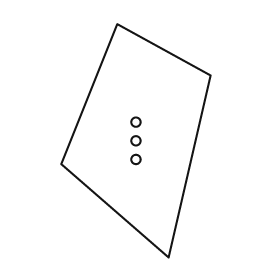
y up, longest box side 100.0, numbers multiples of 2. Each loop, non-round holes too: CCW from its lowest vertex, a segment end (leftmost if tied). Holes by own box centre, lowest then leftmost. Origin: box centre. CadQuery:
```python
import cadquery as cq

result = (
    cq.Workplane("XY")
    .moveTo(14.0, -50.0)
    .lineTo(32.0, 28.0)
    .lineTo(-8.0, 50.0)
    .lineTo(-32.0, -10.0)
    .close()
    .moveTo(0.0, -8.0)
    .circle(2.0)
    .moveTo(0.0, 0.0)
    .circle(2.0)
    .moveTo(0.0, 8.0)
    .circle(2.0)
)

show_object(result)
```